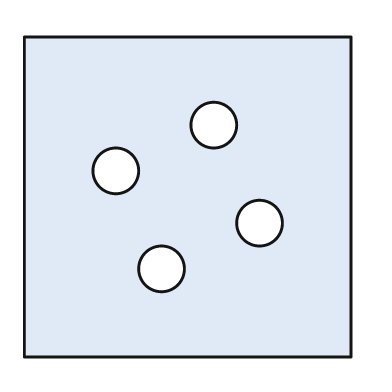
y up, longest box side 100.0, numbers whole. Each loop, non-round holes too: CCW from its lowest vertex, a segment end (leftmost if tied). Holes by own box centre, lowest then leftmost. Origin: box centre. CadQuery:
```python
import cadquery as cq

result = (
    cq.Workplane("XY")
    .moveTo(-50.0, -49.0)
    .lineTo(50.0, -49.0)
    .lineTo(50.0, 49.0)
    .lineTo(-50.0, 49.0)
    .close()
    .moveTo(-8.0, -22.0)
    .circle(7.0)
    .moveTo(22.0, -8.0)
    .circle(7.0)
    .moveTo(-22.0, 8.0)
    .circle(7.0)
    .moveTo(8.0, 22.0)
    .circle(7.0)
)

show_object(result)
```